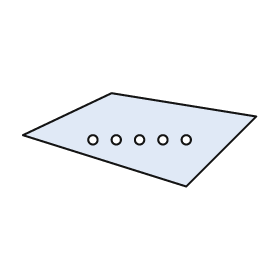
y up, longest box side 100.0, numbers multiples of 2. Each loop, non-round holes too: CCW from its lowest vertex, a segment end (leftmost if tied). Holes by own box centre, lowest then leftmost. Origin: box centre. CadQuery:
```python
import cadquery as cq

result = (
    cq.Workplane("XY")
    .moveTo(20.0, -20.0)
    .lineTo(50.0, 10.0)
    .lineTo(-12.0, 20.0)
    .lineTo(-50.0, 2.0)
    .close()
    .moveTo(-20.0, 0.0)
    .circle(2.0)
    .moveTo(-10.0, 0.0)
    .circle(2.0)
    .moveTo(0.0, 0.0)
    .circle(2.0)
    .moveTo(10.0, 0.0)
    .circle(2.0)
    .moveTo(20.0, 0.0)
    .circle(2.0)
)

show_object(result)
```